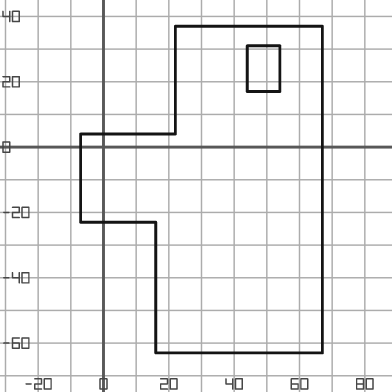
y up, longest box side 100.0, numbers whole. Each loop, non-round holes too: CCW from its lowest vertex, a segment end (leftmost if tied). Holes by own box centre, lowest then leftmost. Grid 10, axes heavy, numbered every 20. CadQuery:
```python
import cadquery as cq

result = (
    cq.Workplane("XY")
    .moveTo(16.0, -63.0)
    .lineTo(67.0, -63.0)
    .lineTo(67.0, 37.0)
    .lineTo(22.0, 37.0)
    .lineTo(22.0, 4.0)
    .lineTo(-7.0, 4.0)
    .lineTo(-7.0, -23.0)
    .lineTo(16.0, -23.0)
    .close()
    .moveTo(44.0, 17.0)
    .lineTo(54.0, 17.0)
    .lineTo(54.0, 31.0)
    .lineTo(44.0, 31.0)
    .close()
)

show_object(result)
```